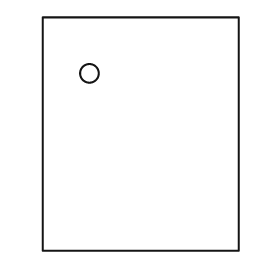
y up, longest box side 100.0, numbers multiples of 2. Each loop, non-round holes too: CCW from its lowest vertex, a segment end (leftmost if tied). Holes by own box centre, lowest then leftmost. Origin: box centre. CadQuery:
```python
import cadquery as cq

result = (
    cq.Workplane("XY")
    .moveTo(-42.0, -50.0)
    .lineTo(42.0, -50.0)
    .lineTo(42.0, 50.0)
    .lineTo(-42.0, 50.0)
    .close()
    .moveTo(-22.0, 26.0)
    .circle(4.0)
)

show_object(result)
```